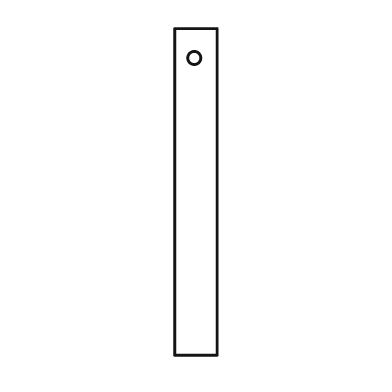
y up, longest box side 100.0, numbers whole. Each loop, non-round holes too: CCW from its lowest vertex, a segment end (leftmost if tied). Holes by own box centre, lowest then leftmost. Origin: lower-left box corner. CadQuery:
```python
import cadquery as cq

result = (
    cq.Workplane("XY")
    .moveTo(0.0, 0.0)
    .lineTo(13.0, 0.0)
    .lineTo(13.0, 100.0)
    .lineTo(0.0, 100.0)
    .close()
    .moveTo(6.0, 91.0)
    .circle(2.0)
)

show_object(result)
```